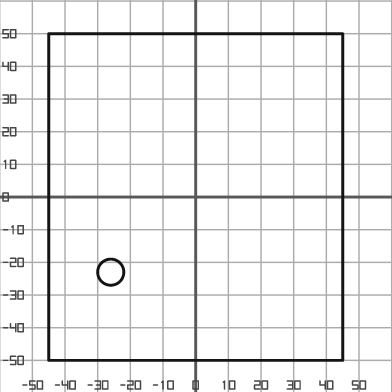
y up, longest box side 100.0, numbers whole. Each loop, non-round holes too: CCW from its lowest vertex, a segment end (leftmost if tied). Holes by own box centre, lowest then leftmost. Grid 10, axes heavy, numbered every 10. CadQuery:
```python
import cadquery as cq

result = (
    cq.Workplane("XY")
    .moveTo(-45.0, -50.0)
    .lineTo(45.0, -50.0)
    .lineTo(45.0, 50.0)
    .lineTo(-45.0, 50.0)
    .close()
    .moveTo(-26.0, -23.0)
    .circle(4.0)
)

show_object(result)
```